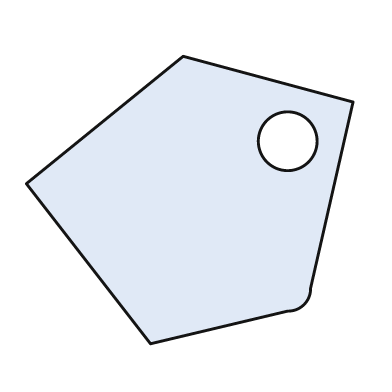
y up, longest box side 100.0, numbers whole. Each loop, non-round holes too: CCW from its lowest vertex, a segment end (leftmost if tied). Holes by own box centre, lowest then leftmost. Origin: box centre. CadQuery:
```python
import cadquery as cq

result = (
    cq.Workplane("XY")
    .moveTo(-12.0, -44.0)
    .lineTo(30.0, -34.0)
    .threePointArc((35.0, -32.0), (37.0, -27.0))
    .lineTo(50.0, 30.0)
    .lineTo(-2.0, 44.0)
    .lineTo(-50.0, 5.0)
    .close()
    .moveTo(30.0, 18.0)
    .circle(9.0)
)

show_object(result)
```